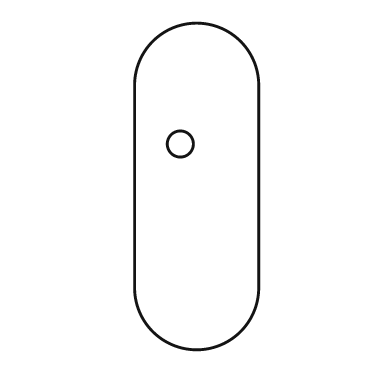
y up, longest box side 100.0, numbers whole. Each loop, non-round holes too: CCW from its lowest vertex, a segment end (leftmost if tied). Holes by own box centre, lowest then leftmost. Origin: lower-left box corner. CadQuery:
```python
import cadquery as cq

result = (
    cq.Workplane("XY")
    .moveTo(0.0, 19.0)
    .threePointArc((19.0, 0.0), (38.0, 19.0))
    .lineTo(38.0, 81.0)
    .threePointArc((19.0, 100.0), (0.0, 81.0))
    .close()
    .moveTo(14.0, 63.0)
    .circle(4.0)
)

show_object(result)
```